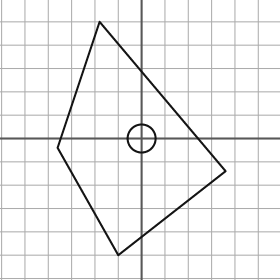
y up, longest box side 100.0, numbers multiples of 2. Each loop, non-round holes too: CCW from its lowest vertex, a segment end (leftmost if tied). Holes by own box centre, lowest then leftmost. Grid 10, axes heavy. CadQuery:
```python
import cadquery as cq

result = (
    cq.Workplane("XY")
    .moveTo(-10.0, -50.0)
    .lineTo(36.0, -14.0)
    .lineTo(-18.0, 50.0)
    .lineTo(-36.0, -4.0)
    .close()
    .moveTo(0.0, 0.0)
    .circle(6.0)
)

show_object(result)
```